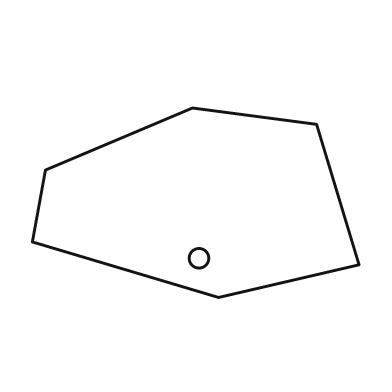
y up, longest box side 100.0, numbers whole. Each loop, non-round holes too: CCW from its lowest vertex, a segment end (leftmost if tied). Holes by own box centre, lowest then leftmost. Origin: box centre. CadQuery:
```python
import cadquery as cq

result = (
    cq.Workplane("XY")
    .moveTo(7.0, -29.0)
    .lineTo(50.0, -19.0)
    .lineTo(37.0, 24.0)
    .lineTo(-1.0, 29.0)
    .lineTo(-46.0, 10.0)
    .lineTo(-50.0, -12.0)
    .close()
    .moveTo(1.0, -17.0)
    .circle(3.0)
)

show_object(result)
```